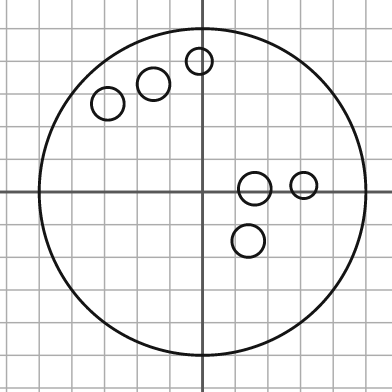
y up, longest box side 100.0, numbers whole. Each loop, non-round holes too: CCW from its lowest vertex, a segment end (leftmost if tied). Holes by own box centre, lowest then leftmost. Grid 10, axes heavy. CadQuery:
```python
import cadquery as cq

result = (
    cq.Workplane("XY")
    .moveTo(0.0, 0.0)
    .circle(50.0)
    .moveTo(14.0, -15.0)
    .circle(5.0)
    .moveTo(16.0, 1.0)
    .circle(5.0)
    .moveTo(31.0, 2.0)
    .circle(4.0)
    .moveTo(-29.0, 27.0)
    .circle(5.0)
    .moveTo(-15.0, 33.0)
    .circle(5.0)
    .moveTo(-1.0, 40.0)
    .circle(4.0)
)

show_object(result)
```